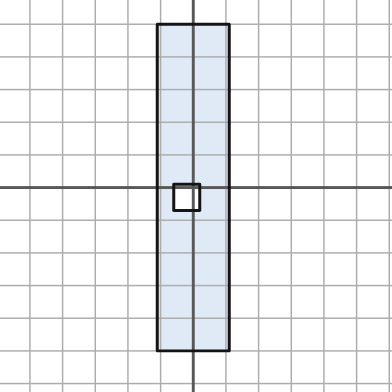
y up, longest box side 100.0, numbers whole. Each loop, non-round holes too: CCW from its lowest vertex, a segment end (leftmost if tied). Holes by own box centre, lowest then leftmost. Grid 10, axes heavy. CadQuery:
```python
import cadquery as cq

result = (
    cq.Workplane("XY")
    .moveTo(-11.0, -50.0)
    .lineTo(11.0, -50.0)
    .lineTo(11.0, 50.0)
    .lineTo(-11.0, 50.0)
    .close()
    .moveTo(-6.0, -7.0)
    .lineTo(2.0, -7.0)
    .lineTo(2.0, 1.0)
    .lineTo(-6.0, 1.0)
    .close()
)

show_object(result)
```